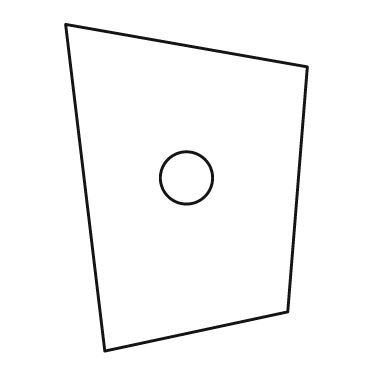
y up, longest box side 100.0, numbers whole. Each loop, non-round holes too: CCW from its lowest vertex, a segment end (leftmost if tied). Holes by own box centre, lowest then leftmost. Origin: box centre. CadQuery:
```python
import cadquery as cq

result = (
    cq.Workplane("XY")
    .moveTo(-25.0, -50.0)
    .lineTo(31.0, -38.0)
    .lineTo(37.0, 37.0)
    .lineTo(-37.0, 50.0)
    .close()
    .moveTo(0.0, 3.0)
    .circle(8.0)
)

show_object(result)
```